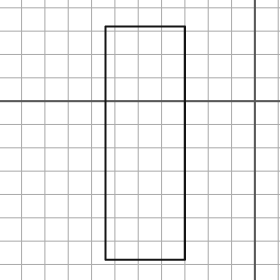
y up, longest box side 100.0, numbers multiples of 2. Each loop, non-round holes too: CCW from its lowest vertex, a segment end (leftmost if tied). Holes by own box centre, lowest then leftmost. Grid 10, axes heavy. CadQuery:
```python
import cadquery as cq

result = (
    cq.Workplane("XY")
    .moveTo(-64.0, -68.0)
    .lineTo(-30.0, -68.0)
    .lineTo(-30.0, 32.0)
    .lineTo(-64.0, 32.0)
    .close()
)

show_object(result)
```